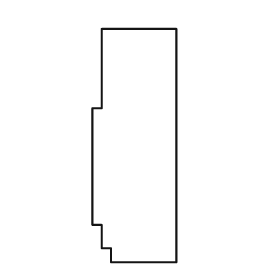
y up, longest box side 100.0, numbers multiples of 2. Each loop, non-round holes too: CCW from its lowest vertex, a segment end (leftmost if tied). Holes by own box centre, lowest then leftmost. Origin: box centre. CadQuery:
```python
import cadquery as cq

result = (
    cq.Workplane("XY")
    .moveTo(-10.0, -50.0)
    .lineTo(18.0, -50.0)
    .lineTo(18.0, 50.0)
    .lineTo(-14.0, 50.0)
    .lineTo(-14.0, 16.0)
    .lineTo(-18.0, 16.0)
    .lineTo(-18.0, -34.0)
    .lineTo(-14.0, -34.0)
    .lineTo(-14.0, -44.0)
    .lineTo(-10.0, -44.0)
    .close()
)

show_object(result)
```